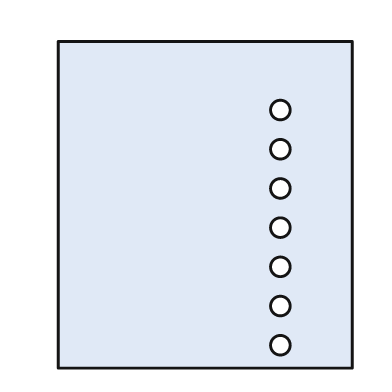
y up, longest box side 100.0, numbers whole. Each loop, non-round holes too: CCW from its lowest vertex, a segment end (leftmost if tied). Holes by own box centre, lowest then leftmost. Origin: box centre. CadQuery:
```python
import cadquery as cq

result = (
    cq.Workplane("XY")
    .moveTo(-45.0, -50.0)
    .lineTo(45.0, -50.0)
    .lineTo(45.0, 50.0)
    .lineTo(-45.0, 50.0)
    .close()
    .moveTo(23.0, -43.0)
    .circle(3.0)
    .moveTo(23.0, -31.0)
    .circle(3.0)
    .moveTo(23.0, -19.0)
    .circle(3.0)
    .moveTo(23.0, -7.0)
    .circle(3.0)
    .moveTo(23.0, 5.0)
    .circle(3.0)
    .moveTo(23.0, 17.0)
    .circle(3.0)
    .moveTo(23.0, 29.0)
    .circle(3.0)
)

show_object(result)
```